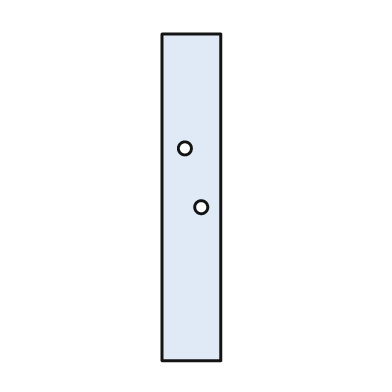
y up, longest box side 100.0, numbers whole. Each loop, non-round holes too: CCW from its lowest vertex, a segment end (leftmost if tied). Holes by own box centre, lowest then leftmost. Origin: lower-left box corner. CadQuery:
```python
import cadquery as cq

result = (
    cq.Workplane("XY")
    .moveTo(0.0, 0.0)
    .lineTo(18.0, 0.0)
    .lineTo(18.0, 100.0)
    .lineTo(0.0, 100.0)
    .close()
    .moveTo(12.0, 47.0)
    .circle(2.0)
    .moveTo(7.0, 65.0)
    .circle(2.0)
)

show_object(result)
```